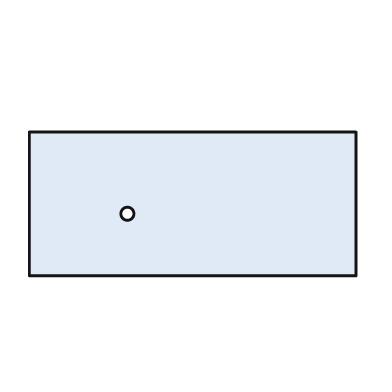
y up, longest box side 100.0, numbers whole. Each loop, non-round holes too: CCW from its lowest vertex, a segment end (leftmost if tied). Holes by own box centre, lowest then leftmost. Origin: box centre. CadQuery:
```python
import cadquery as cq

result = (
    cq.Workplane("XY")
    .moveTo(-50.0, -22.0)
    .lineTo(50.0, -22.0)
    .lineTo(50.0, 22.0)
    .lineTo(-50.0, 22.0)
    .close()
    .moveTo(-20.0, -3.0)
    .circle(2.0)
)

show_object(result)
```